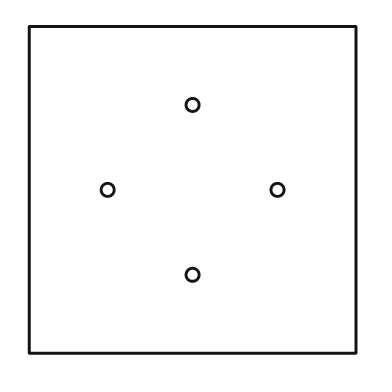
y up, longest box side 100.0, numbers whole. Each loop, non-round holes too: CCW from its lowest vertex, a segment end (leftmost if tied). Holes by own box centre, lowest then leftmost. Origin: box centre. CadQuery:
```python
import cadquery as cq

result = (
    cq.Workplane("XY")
    .moveTo(-50.0, -50.0)
    .lineTo(50.0, -50.0)
    .lineTo(50.0, 50.0)
    .lineTo(-50.0, 50.0)
    .close()
    .moveTo(0.0, -26.0)
    .circle(2.0)
    .moveTo(-26.0, 0.0)
    .circle(2.0)
    .moveTo(26.0, 0.0)
    .circle(2.0)
    .moveTo(0.0, 26.0)
    .circle(2.0)
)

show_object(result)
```